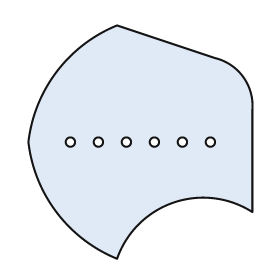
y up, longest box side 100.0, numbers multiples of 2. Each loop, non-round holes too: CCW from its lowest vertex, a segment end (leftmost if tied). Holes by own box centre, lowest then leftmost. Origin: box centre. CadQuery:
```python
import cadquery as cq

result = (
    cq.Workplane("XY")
    .moveTo(-10.0, -50.0)
    .threePointArc((14.0, -26.0), (48.0, -30.0))
    .lineTo(48.0, 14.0)
    .threePointArc((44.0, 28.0), (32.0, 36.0))
    .lineTo(-10.0, 50.0)
    .threePointArc((-36.0, 30.0), (-48.0, 0.0))
    .threePointArc((-36.0, -30.0), (-10.0, -50.0))
    .close()
    .moveTo(-30.0, 0.0)
    .circle(2.0)
    .moveTo(-18.0, 0.0)
    .circle(2.0)
    .moveTo(-6.0, 0.0)
    .circle(2.0)
    .moveTo(6.0, 0.0)
    .circle(2.0)
    .moveTo(18.0, 0.0)
    .circle(2.0)
    .moveTo(30.0, 0.0)
    .circle(2.0)
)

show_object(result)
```